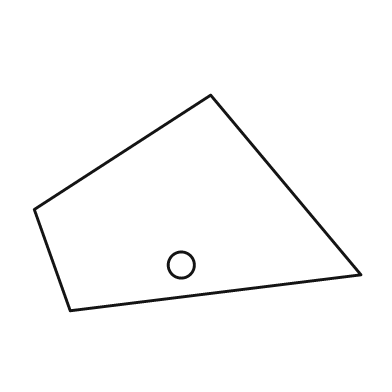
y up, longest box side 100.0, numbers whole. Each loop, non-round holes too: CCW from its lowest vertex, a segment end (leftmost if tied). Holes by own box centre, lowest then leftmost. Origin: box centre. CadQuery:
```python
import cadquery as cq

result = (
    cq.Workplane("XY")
    .moveTo(-39.0, -33.0)
    .lineTo(50.0, -22.0)
    .lineTo(4.0, 33.0)
    .lineTo(-50.0, -2.0)
    .close()
    .moveTo(-5.0, -19.0)
    .circle(4.0)
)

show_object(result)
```